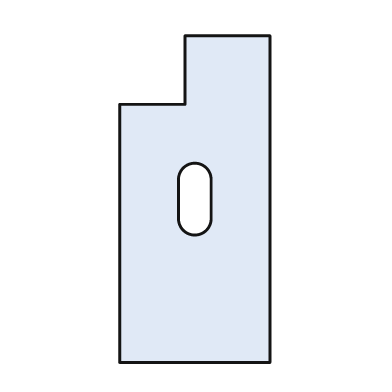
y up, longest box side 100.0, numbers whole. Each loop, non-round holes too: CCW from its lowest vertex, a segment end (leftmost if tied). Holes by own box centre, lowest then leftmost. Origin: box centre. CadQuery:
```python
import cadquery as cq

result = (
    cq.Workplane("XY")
    .moveTo(-23.0, -50.0)
    .lineTo(23.0, -50.0)
    .lineTo(23.0, 50.0)
    .lineTo(-3.0, 50.0)
    .lineTo(-3.0, 29.0)
    .lineTo(-23.0, 29.0)
    .close()
    .moveTo(-5.0, -6.0)
    .threePointArc((0.0, -11.0), (5.0, -6.0))
    .lineTo(5.0, 6.0)
    .threePointArc((0.0, 11.0), (-5.0, 6.0))
    .close()
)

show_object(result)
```